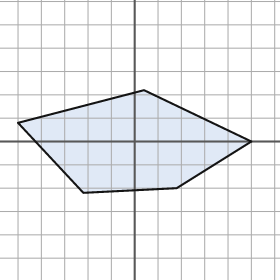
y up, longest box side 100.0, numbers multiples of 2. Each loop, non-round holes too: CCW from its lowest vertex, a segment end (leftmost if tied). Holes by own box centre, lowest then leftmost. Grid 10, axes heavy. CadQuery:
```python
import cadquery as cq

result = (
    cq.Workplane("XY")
    .moveTo(-22.0, -22.0)
    .lineTo(18.0, -20.0)
    .lineTo(50.0, 0.0)
    .lineTo(4.0, 22.0)
    .lineTo(-50.0, 8.0)
    .close()
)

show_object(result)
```